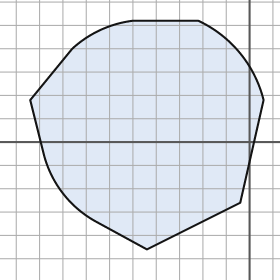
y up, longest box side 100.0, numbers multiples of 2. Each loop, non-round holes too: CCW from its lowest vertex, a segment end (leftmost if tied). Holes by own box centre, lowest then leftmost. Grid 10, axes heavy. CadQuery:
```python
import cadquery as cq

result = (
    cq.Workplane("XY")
    .moveTo(-44.0, -46.0)
    .lineTo(-4.0, -26.0)
    .lineTo(6.0, 18.0)
    .threePointArc((-4.0, 38.0), (-22.0, 52.0))
    .lineTo(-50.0, 52.0)
    .threePointArc((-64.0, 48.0), (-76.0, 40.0))
    .lineTo(-94.0, 18.0)
    .lineTo(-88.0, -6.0)
    .threePointArc((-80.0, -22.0), (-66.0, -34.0))
    .close()
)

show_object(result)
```